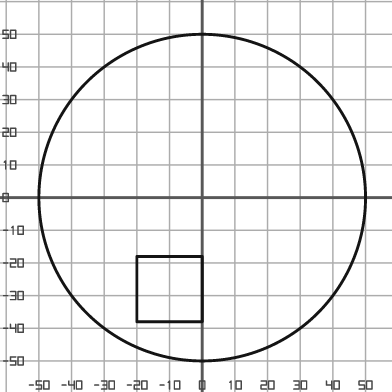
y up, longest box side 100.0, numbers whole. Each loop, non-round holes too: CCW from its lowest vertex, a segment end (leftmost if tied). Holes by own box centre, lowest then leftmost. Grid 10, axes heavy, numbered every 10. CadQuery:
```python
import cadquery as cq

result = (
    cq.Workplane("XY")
    .moveTo(0.0, 0.0)
    .circle(50.0)
    .moveTo(-20.0, -38.0)
    .lineTo(0.0, -38.0)
    .lineTo(0.0, -18.0)
    .lineTo(-20.0, -18.0)
    .close()
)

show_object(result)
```